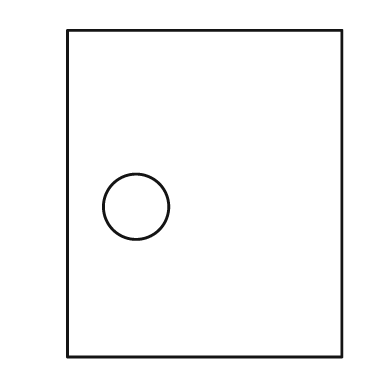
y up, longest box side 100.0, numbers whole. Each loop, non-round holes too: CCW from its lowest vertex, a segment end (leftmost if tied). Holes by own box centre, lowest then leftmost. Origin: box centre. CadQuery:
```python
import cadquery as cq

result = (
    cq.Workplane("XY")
    .moveTo(-42.0, -50.0)
    .lineTo(42.0, -50.0)
    .lineTo(42.0, 50.0)
    .lineTo(-42.0, 50.0)
    .close()
    .moveTo(-21.0, -4.0)
    .circle(10.0)
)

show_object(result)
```